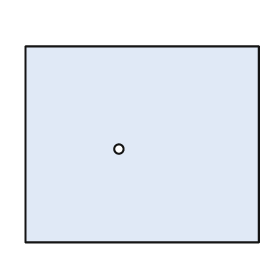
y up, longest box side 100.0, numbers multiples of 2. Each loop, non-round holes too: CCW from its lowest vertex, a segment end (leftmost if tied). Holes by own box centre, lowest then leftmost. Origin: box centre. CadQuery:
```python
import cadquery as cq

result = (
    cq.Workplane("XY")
    .moveTo(-50.0, -42.0)
    .lineTo(50.0, -42.0)
    .lineTo(50.0, 42.0)
    .lineTo(-50.0, 42.0)
    .close()
    .moveTo(-10.0, -2.0)
    .circle(2.0)
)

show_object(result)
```